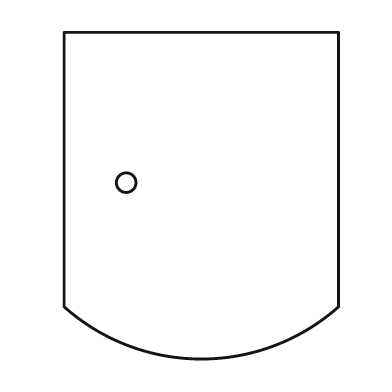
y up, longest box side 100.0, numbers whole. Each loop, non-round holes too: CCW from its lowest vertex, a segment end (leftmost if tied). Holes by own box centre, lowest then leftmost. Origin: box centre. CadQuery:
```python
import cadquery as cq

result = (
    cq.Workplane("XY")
    .moveTo(-42.0, -34.0)
    .threePointArc((0.0, -50.0), (42.0, -34.0))
    .lineTo(42.0, 50.0)
    .lineTo(-42.0, 50.0)
    .close()
    .moveTo(-23.0, 4.0)
    .circle(3.0)
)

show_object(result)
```